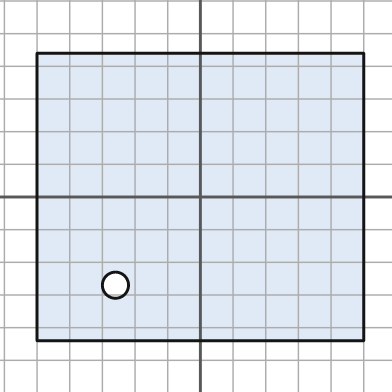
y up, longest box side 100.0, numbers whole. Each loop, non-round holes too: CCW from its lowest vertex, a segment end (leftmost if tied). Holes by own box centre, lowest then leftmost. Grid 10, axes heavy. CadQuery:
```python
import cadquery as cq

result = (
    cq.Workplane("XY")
    .moveTo(-50.0, -44.0)
    .lineTo(50.0, -44.0)
    .lineTo(50.0, 44.0)
    .lineTo(-50.0, 44.0)
    .close()
    .moveTo(-26.0, -27.0)
    .circle(4.0)
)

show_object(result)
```